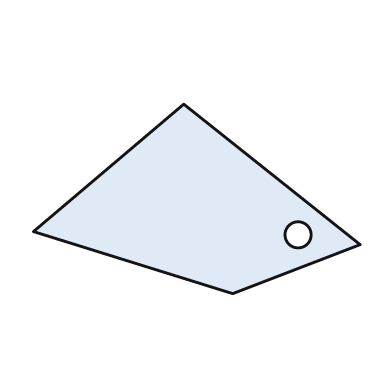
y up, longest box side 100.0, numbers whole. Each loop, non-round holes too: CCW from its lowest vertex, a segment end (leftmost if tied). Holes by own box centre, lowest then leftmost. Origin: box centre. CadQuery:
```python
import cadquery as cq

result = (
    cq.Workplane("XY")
    .moveTo(11.0, -29.0)
    .lineTo(50.0, -14.0)
    .lineTo(-4.0, 29.0)
    .lineTo(-50.0, -10.0)
    .close()
    .moveTo(31.0, -11.0)
    .circle(4.0)
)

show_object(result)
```